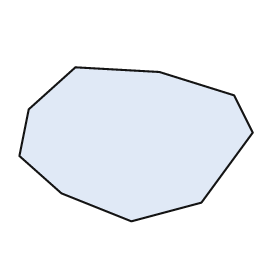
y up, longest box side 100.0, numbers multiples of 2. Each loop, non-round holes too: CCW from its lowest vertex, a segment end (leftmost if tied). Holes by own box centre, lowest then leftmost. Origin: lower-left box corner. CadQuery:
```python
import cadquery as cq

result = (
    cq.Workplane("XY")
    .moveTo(48.0, 0.0)
    .lineTo(78.0, 8.0)
    .lineTo(100.0, 38.0)
    .lineTo(92.0, 54.0)
    .lineTo(60.0, 64.0)
    .lineTo(24.0, 66.0)
    .lineTo(4.0, 48.0)
    .lineTo(0.0, 28.0)
    .lineTo(18.0, 12.0)
    .close()
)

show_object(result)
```